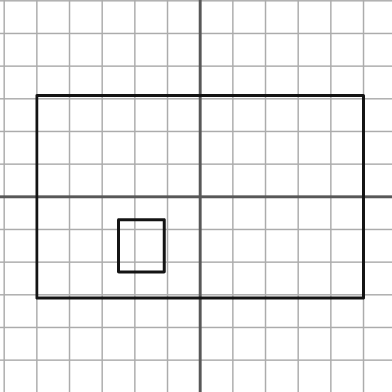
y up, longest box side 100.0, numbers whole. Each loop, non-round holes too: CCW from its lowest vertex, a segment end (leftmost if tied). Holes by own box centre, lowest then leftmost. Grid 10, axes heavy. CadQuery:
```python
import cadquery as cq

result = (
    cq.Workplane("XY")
    .moveTo(-50.0, -31.0)
    .lineTo(50.0, -31.0)
    .lineTo(50.0, 31.0)
    .lineTo(-50.0, 31.0)
    .close()
    .moveTo(-25.0, -23.0)
    .lineTo(-11.0, -23.0)
    .lineTo(-11.0, -7.0)
    .lineTo(-25.0, -7.0)
    .close()
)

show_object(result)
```